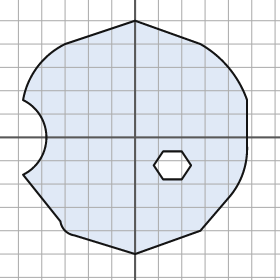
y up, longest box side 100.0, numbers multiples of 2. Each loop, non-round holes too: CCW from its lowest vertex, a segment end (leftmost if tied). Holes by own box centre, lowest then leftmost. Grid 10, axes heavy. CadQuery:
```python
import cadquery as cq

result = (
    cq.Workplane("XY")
    .moveTo(0.0, -50.0)
    .lineTo(28.0, -40.0)
    .lineTo(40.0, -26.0)
    .threePointArc((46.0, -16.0), (48.0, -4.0))
    .lineTo(48.0, 16.0)
    .threePointArc((40.0, 30.0), (28.0, 40.0))
    .lineTo(0.0, 50.0)
    .lineTo(-30.0, 40.0)
    .threePointArc((-42.0, 30.0), (-48.0, 16.0))
    .threePointArc((-38.0, 0.0), (-48.0, -16.0))
    .lineTo(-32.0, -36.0)
    .threePointArc((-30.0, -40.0), (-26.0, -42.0))
    .close()
    .moveTo(12.0, -18.0)
    .lineTo(20.0, -18.0)
    .lineTo(24.0, -12.0)
    .lineTo(20.0, -6.0)
    .lineTo(12.0, -6.0)
    .lineTo(8.0, -12.0)
    .close()
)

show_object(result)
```